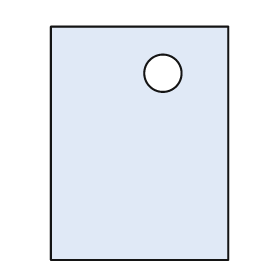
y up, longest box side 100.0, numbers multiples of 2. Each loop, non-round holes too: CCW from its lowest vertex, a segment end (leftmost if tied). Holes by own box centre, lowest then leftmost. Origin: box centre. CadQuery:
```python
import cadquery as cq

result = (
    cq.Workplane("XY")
    .moveTo(-38.0, -50.0)
    .lineTo(38.0, -50.0)
    .lineTo(38.0, 50.0)
    .lineTo(-38.0, 50.0)
    .close()
    .moveTo(10.0, 30.0)
    .circle(8.0)
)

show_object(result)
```